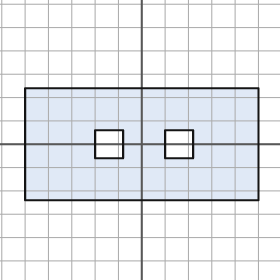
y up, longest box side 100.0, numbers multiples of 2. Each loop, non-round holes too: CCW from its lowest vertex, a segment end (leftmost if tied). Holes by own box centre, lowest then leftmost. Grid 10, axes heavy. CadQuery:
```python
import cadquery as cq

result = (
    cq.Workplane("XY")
    .moveTo(-50.0, -24.0)
    .lineTo(50.0, -24.0)
    .lineTo(50.0, 24.0)
    .lineTo(-50.0, 24.0)
    .close()
    .moveTo(-20.0, -6.0)
    .lineTo(-8.0, -6.0)
    .lineTo(-8.0, 6.0)
    .lineTo(-20.0, 6.0)
    .close()
    .moveTo(10.0, -6.0)
    .lineTo(22.0, -6.0)
    .lineTo(22.0, 6.0)
    .lineTo(10.0, 6.0)
    .close()
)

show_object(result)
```